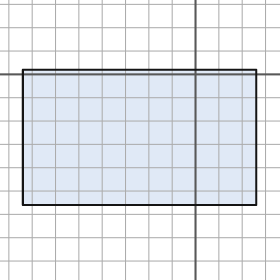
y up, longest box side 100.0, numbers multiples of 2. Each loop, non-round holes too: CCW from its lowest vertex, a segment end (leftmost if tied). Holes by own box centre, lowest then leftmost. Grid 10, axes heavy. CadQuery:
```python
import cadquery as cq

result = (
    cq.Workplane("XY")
    .moveTo(-74.0, -56.0)
    .lineTo(26.0, -56.0)
    .lineTo(26.0, 2.0)
    .lineTo(-74.0, 2.0)
    .close()
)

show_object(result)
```